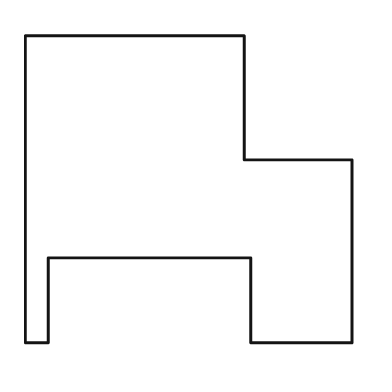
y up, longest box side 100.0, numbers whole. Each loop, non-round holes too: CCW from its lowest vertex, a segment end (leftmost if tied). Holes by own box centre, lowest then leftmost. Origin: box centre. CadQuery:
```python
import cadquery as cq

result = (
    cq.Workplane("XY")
    .moveTo(-50.0, -47.0)
    .lineTo(-43.0, -47.0)
    .lineTo(-43.0, -21.0)
    .lineTo(19.0, -21.0)
    .lineTo(19.0, -47.0)
    .lineTo(50.0, -47.0)
    .lineTo(50.0, 9.0)
    .lineTo(17.0, 9.0)
    .lineTo(17.0, 47.0)
    .lineTo(-50.0, 47.0)
    .close()
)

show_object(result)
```